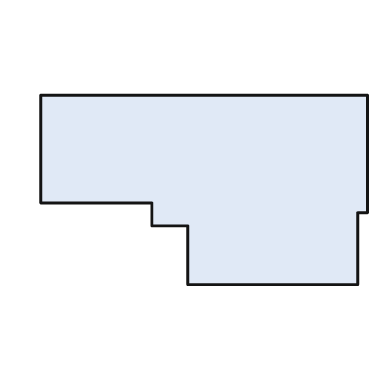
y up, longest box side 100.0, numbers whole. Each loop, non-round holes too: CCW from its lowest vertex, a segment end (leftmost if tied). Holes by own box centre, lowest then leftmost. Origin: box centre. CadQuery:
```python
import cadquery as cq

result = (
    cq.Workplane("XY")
    .moveTo(-5.0, -29.0)
    .lineTo(47.0, -29.0)
    .lineTo(47.0, -7.0)
    .lineTo(50.0, -7.0)
    .lineTo(50.0, 29.0)
    .lineTo(-50.0, 29.0)
    .lineTo(-50.0, -4.0)
    .lineTo(-16.0, -4.0)
    .lineTo(-16.0, -11.0)
    .lineTo(-5.0, -11.0)
    .close()
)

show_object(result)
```